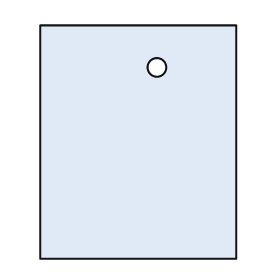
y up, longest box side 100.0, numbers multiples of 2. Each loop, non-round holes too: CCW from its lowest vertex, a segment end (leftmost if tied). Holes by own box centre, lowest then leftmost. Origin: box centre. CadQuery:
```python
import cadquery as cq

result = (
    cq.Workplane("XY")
    .moveTo(-42.0, -50.0)
    .lineTo(42.0, -50.0)
    .lineTo(42.0, 50.0)
    .lineTo(-42.0, 50.0)
    .close()
    .moveTo(8.0, 32.0)
    .circle(4.0)
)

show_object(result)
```